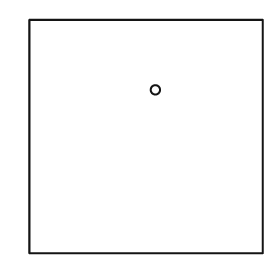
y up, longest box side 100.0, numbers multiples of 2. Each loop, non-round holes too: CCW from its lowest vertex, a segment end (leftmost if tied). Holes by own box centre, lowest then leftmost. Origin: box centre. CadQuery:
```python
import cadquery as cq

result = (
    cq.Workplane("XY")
    .moveTo(-50.0, -50.0)
    .lineTo(50.0, -50.0)
    .lineTo(50.0, 50.0)
    .lineTo(-50.0, 50.0)
    .close()
    .moveTo(4.0, 20.0)
    .circle(2.0)
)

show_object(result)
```